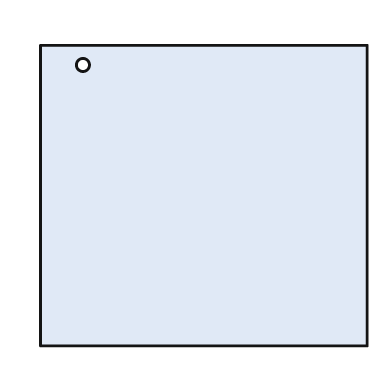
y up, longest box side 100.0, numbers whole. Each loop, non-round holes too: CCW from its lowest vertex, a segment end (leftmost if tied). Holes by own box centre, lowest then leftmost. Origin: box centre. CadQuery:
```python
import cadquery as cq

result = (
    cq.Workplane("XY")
    .moveTo(-50.0, -46.0)
    .lineTo(50.0, -46.0)
    .lineTo(50.0, 46.0)
    .lineTo(-50.0, 46.0)
    .close()
    .moveTo(-37.0, 40.0)
    .circle(2.0)
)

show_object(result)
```